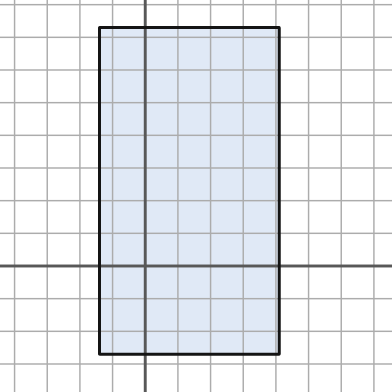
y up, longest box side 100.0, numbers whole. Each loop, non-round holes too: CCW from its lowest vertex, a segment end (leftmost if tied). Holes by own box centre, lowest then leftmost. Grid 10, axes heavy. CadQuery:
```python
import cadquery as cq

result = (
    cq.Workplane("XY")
    .moveTo(-14.0, -27.0)
    .lineTo(41.0, -27.0)
    .lineTo(41.0, 73.0)
    .lineTo(-14.0, 73.0)
    .close()
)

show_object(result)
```